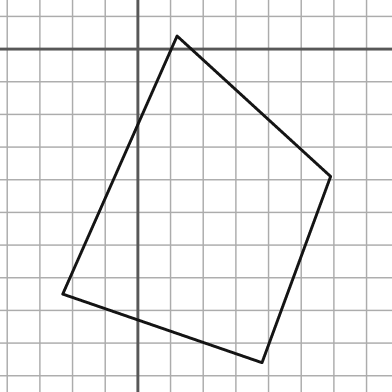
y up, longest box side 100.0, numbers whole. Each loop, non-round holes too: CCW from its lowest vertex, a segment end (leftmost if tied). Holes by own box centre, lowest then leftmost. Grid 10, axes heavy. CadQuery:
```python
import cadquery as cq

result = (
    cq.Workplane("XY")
    .moveTo(38.0, -96.0)
    .lineTo(59.0, -39.0)
    .lineTo(12.0, 4.0)
    .lineTo(-23.0, -75.0)
    .close()
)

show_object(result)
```